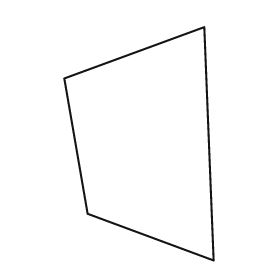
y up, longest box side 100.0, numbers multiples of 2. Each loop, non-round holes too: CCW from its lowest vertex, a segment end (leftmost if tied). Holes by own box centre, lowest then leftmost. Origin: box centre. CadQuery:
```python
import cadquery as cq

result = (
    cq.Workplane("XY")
    .moveTo(32.0, -50.0)
    .lineTo(28.0, 50.0)
    .lineTo(-32.0, 28.0)
    .lineTo(-22.0, -30.0)
    .close()
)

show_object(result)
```